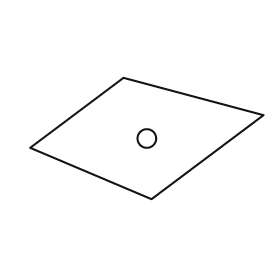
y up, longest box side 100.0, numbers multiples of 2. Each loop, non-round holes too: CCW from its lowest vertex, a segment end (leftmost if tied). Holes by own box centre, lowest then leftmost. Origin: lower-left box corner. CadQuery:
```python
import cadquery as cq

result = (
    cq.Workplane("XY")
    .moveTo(52.0, 0.0)
    .lineTo(100.0, 36.0)
    .lineTo(40.0, 52.0)
    .lineTo(0.0, 22.0)
    .close()
    .moveTo(50.0, 26.0)
    .circle(4.0)
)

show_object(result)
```